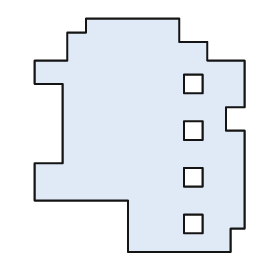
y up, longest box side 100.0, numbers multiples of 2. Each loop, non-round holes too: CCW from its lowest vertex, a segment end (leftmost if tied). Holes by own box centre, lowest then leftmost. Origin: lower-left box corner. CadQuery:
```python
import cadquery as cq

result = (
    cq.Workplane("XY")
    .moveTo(40.0, 0.0)
    .lineTo(84.0, 0.0)
    .lineTo(84.0, 10.0)
    .lineTo(90.0, 10.0)
    .lineTo(90.0, 52.0)
    .lineTo(82.0, 52.0)
    .lineTo(82.0, 62.0)
    .lineTo(90.0, 62.0)
    .lineTo(90.0, 82.0)
    .lineTo(74.0, 82.0)
    .lineTo(74.0, 90.0)
    .lineTo(62.0, 90.0)
    .lineTo(62.0, 100.0)
    .lineTo(22.0, 100.0)
    .lineTo(22.0, 94.0)
    .lineTo(14.0, 94.0)
    .lineTo(14.0, 82.0)
    .lineTo(0.0, 82.0)
    .lineTo(0.0, 72.0)
    .lineTo(12.0, 72.0)
    .lineTo(12.0, 38.0)
    .lineTo(0.0, 38.0)
    .lineTo(0.0, 22.0)
    .lineTo(40.0, 22.0)
    .close()
    .moveTo(64.0, 8.0)
    .lineTo(72.0, 8.0)
    .lineTo(72.0, 16.0)
    .lineTo(64.0, 16.0)
    .close()
    .moveTo(64.0, 28.0)
    .lineTo(72.0, 28.0)
    .lineTo(72.0, 36.0)
    .lineTo(64.0, 36.0)
    .close()
    .moveTo(64.0, 48.0)
    .lineTo(72.0, 48.0)
    .lineTo(72.0, 56.0)
    .lineTo(64.0, 56.0)
    .close()
    .moveTo(64.0, 68.0)
    .lineTo(72.0, 68.0)
    .lineTo(72.0, 76.0)
    .lineTo(64.0, 76.0)
    .close()
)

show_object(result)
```